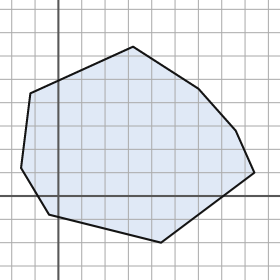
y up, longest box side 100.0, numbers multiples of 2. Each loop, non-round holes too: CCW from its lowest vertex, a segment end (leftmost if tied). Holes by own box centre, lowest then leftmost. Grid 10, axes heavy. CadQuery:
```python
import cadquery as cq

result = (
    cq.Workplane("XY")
    .moveTo(44.0, -20.0)
    .lineTo(84.0, 10.0)
    .lineTo(76.0, 28.0)
    .lineTo(60.0, 46.0)
    .lineTo(32.0, 64.0)
    .lineTo(-12.0, 44.0)
    .lineTo(-16.0, 12.0)
    .lineTo(-4.0, -8.0)
    .close()
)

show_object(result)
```